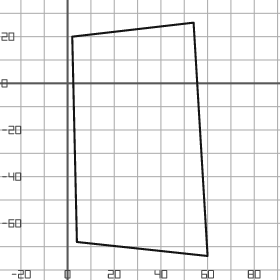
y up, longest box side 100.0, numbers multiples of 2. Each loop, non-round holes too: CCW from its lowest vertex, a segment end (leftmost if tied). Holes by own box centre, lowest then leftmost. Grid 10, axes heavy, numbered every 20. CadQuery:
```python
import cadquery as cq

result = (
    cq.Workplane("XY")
    .moveTo(60.0, -74.0)
    .lineTo(54.0, 26.0)
    .lineTo(2.0, 20.0)
    .lineTo(4.0, -68.0)
    .close()
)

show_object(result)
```